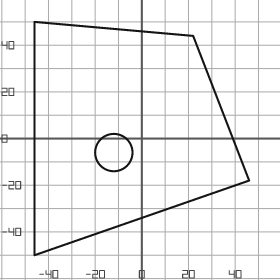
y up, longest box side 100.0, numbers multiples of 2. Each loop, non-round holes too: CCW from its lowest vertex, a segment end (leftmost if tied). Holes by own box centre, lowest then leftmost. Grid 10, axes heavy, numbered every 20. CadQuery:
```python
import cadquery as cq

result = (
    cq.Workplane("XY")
    .moveTo(-46.0, -50.0)
    .lineTo(46.0, -18.0)
    .lineTo(22.0, 44.0)
    .lineTo(-46.0, 50.0)
    .close()
    .moveTo(-12.0, -6.0)
    .circle(8.0)
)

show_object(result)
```